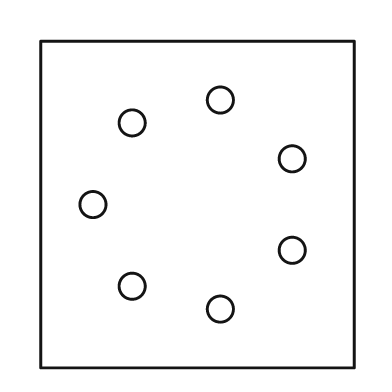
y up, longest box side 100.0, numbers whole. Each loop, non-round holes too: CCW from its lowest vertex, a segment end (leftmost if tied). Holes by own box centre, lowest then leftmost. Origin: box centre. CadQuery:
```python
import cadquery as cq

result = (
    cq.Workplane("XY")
    .moveTo(-48.0, -50.0)
    .lineTo(48.0, -50.0)
    .lineTo(48.0, 50.0)
    .lineTo(-48.0, 50.0)
    .close()
    .moveTo(7.0, -32.0)
    .circle(4.0)
    .moveTo(-20.0, -25.0)
    .circle(4.0)
    .moveTo(29.0, -14.0)
    .circle(4.0)
    .moveTo(-32.0, 0.0)
    .circle(4.0)
    .moveTo(29.0, 14.0)
    .circle(4.0)
    .moveTo(-20.0, 25.0)
    .circle(4.0)
    .moveTo(7.0, 32.0)
    .circle(4.0)
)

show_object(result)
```